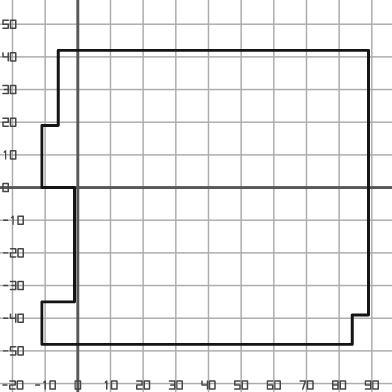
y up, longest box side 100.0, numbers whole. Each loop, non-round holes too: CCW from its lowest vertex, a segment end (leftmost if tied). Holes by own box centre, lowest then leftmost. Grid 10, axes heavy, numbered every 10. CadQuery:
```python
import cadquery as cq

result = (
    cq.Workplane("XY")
    .moveTo(-11.0, -48.0)
    .lineTo(84.0, -48.0)
    .lineTo(84.0, -39.0)
    .lineTo(89.0, -39.0)
    .lineTo(89.0, 42.0)
    .lineTo(-6.0, 42.0)
    .lineTo(-6.0, 19.0)
    .lineTo(-11.0, 19.0)
    .lineTo(-11.0, 0.0)
    .lineTo(-1.0, 0.0)
    .lineTo(-1.0, -35.0)
    .lineTo(-11.0, -35.0)
    .close()
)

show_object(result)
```